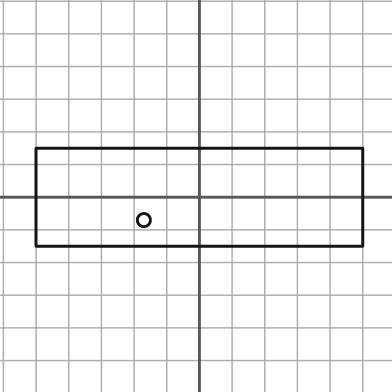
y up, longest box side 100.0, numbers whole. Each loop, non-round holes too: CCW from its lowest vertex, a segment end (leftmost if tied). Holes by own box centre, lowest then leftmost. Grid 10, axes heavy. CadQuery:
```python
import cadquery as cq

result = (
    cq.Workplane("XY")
    .moveTo(-50.0, -15.0)
    .lineTo(50.0, -15.0)
    .lineTo(50.0, 15.0)
    .lineTo(-50.0, 15.0)
    .close()
    .moveTo(-17.0, -7.0)
    .circle(2.0)
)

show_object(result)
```